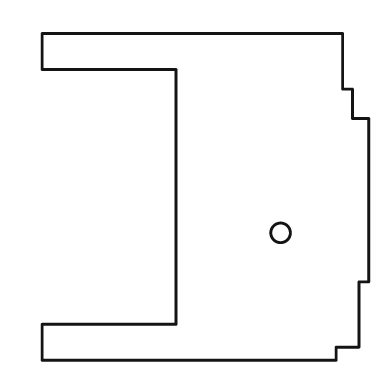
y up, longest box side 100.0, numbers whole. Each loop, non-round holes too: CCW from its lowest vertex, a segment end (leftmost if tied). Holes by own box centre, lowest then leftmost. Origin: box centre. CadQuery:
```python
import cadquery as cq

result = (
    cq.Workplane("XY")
    .moveTo(-50.0, -50.0)
    .lineTo(40.0, -50.0)
    .lineTo(40.0, -46.0)
    .lineTo(47.0, -46.0)
    .lineTo(47.0, -26.0)
    .lineTo(50.0, -26.0)
    .lineTo(50.0, 24.0)
    .lineTo(45.0, 24.0)
    .lineTo(45.0, 33.0)
    .lineTo(42.0, 33.0)
    .lineTo(42.0, 50.0)
    .lineTo(-50.0, 50.0)
    .lineTo(-50.0, 39.0)
    .lineTo(-9.0, 39.0)
    .lineTo(-9.0, -39.0)
    .lineTo(-50.0, -39.0)
    .close()
    .moveTo(23.0, -11.0)
    .circle(3.0)
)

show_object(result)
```